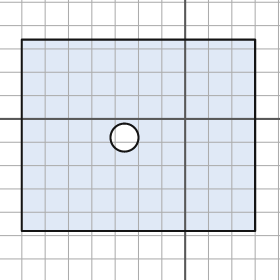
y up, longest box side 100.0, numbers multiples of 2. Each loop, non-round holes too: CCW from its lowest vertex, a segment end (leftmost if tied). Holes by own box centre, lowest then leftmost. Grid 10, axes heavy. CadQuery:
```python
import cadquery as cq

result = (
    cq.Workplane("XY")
    .moveTo(-70.0, -48.0)
    .lineTo(30.0, -48.0)
    .lineTo(30.0, 34.0)
    .lineTo(-70.0, 34.0)
    .close()
    .moveTo(-26.0, -8.0)
    .circle(6.0)
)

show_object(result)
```